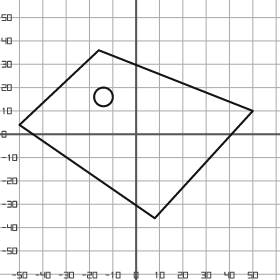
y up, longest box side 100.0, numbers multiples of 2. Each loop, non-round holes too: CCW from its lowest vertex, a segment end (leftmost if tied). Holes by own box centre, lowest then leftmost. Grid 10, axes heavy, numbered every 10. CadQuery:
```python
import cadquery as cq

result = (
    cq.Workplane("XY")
    .moveTo(8.0, -36.0)
    .lineTo(50.0, 10.0)
    .lineTo(-16.0, 36.0)
    .lineTo(-50.0, 4.0)
    .close()
    .moveTo(-14.0, 16.0)
    .circle(4.0)
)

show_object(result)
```